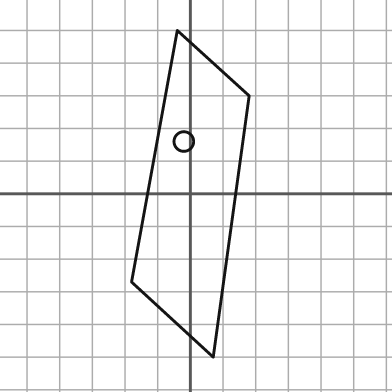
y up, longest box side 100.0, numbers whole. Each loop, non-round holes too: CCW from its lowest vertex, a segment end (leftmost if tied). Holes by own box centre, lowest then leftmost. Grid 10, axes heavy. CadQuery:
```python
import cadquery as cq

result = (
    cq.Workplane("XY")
    .moveTo(7.0, -50.0)
    .lineTo(18.0, 30.0)
    .lineTo(-4.0, 50.0)
    .lineTo(-18.0, -27.0)
    .close()
    .moveTo(-2.0, 16.0)
    .circle(3.0)
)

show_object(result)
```